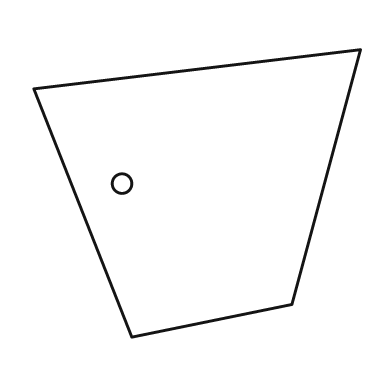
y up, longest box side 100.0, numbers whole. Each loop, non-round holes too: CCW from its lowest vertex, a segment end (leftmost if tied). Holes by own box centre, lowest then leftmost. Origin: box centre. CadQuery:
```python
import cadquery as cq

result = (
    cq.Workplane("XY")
    .moveTo(-20.0, -44.0)
    .lineTo(29.0, -34.0)
    .lineTo(50.0, 44.0)
    .lineTo(-50.0, 32.0)
    .close()
    .moveTo(-23.0, 3.0)
    .circle(3.0)
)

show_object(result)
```